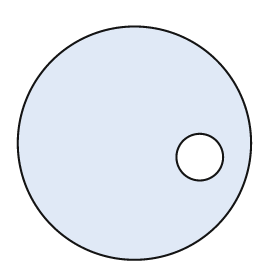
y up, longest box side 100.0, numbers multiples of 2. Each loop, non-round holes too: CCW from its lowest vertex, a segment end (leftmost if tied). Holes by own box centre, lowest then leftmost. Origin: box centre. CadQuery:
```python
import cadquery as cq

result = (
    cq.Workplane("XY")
    .moveTo(0.0, 0.0)
    .circle(50.0)
    .moveTo(28.0, -6.0)
    .circle(10.0)
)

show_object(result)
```